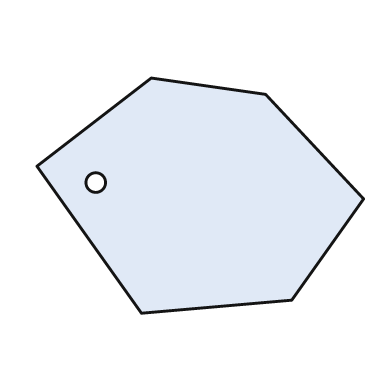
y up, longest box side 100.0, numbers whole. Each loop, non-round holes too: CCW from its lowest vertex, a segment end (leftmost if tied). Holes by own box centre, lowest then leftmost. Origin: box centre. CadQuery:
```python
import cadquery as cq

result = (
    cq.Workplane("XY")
    .moveTo(-18.0, -36.0)
    .lineTo(28.0, -32.0)
    .lineTo(50.0, -1.0)
    .lineTo(20.0, 31.0)
    .lineTo(-15.0, 36.0)
    .lineTo(-50.0, 9.0)
    .close()
    .moveTo(-32.0, 4.0)
    .circle(3.0)
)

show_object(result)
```